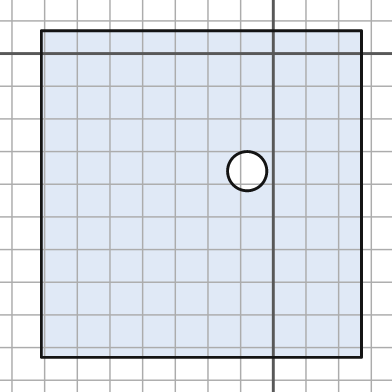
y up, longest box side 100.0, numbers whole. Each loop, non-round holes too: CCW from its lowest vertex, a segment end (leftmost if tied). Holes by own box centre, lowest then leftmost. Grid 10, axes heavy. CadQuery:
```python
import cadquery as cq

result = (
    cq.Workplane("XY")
    .moveTo(-71.0, -93.0)
    .lineTo(27.0, -93.0)
    .lineTo(27.0, 7.0)
    .lineTo(-71.0, 7.0)
    .close()
    .moveTo(-8.0, -36.0)
    .circle(6.0)
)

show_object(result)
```